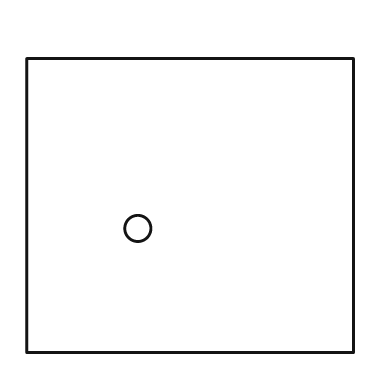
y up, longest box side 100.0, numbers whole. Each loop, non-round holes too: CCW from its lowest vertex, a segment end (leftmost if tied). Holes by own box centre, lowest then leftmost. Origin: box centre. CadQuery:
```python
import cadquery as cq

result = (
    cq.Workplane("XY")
    .moveTo(-50.0, -45.0)
    .lineTo(50.0, -45.0)
    .lineTo(50.0, 45.0)
    .lineTo(-50.0, 45.0)
    .close()
    .moveTo(-16.0, -7.0)
    .circle(4.0)
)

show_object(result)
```